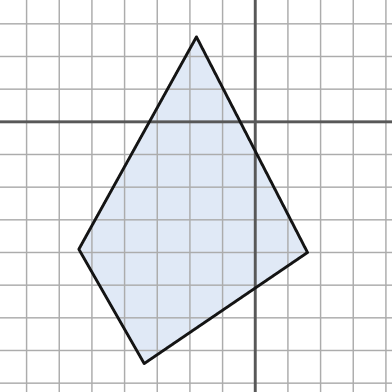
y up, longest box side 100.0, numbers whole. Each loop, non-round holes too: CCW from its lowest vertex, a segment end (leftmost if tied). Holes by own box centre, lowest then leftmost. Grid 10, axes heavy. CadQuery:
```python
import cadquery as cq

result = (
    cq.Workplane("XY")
    .moveTo(-34.0, -74.0)
    .lineTo(16.0, -40.0)
    .lineTo(-18.0, 26.0)
    .lineTo(-54.0, -39.0)
    .close()
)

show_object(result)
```